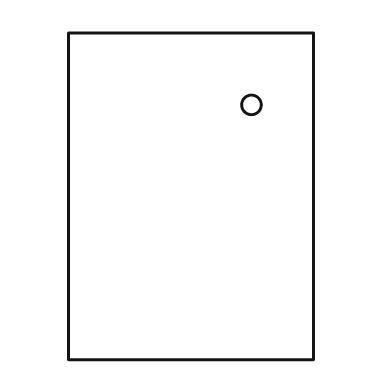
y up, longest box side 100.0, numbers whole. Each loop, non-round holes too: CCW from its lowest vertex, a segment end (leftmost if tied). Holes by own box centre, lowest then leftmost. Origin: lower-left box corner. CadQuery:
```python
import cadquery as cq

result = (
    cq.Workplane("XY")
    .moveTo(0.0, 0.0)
    .lineTo(75.0, 0.0)
    .lineTo(75.0, 100.0)
    .lineTo(0.0, 100.0)
    .close()
    .moveTo(56.0, 78.0)
    .circle(3.0)
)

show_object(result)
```